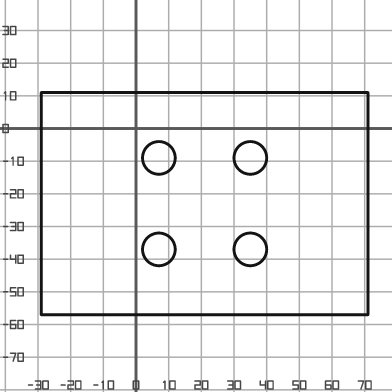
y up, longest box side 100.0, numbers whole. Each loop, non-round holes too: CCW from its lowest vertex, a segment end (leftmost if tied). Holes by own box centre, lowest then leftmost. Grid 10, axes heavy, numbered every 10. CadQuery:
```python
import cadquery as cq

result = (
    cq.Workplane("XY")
    .moveTo(-29.0, -57.0)
    .lineTo(71.0, -57.0)
    .lineTo(71.0, 11.0)
    .lineTo(-29.0, 11.0)
    .close()
    .moveTo(7.0, -37.0)
    .circle(5.0)
    .moveTo(35.0, -37.0)
    .circle(5.0)
    .moveTo(7.0, -9.0)
    .circle(5.0)
    .moveTo(35.0, -9.0)
    .circle(5.0)
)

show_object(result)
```